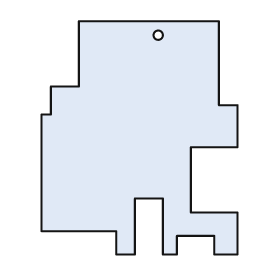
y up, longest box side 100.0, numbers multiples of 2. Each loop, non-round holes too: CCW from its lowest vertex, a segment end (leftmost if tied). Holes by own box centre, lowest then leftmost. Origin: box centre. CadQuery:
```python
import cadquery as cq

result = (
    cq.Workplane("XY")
    .moveTo(-10.0, -50.0)
    .lineTo(-2.0, -50.0)
    .lineTo(-2.0, -26.0)
    .lineTo(10.0, -26.0)
    .lineTo(10.0, -50.0)
    .lineTo(16.0, -50.0)
    .lineTo(16.0, -42.0)
    .lineTo(32.0, -42.0)
    .lineTo(32.0, -50.0)
    .lineTo(42.0, -50.0)
    .lineTo(42.0, -32.0)
    .lineTo(22.0, -32.0)
    .lineTo(22.0, -4.0)
    .lineTo(42.0, -4.0)
    .lineTo(42.0, 14.0)
    .lineTo(34.0, 14.0)
    .lineTo(34.0, 50.0)
    .lineTo(-26.0, 50.0)
    .lineTo(-26.0, 22.0)
    .lineTo(-38.0, 22.0)
    .lineTo(-38.0, 10.0)
    .lineTo(-42.0, 10.0)
    .lineTo(-42.0, -40.0)
    .lineTo(-10.0, -40.0)
    .close()
    .moveTo(8.0, 44.0)
    .circle(2.0)
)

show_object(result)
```